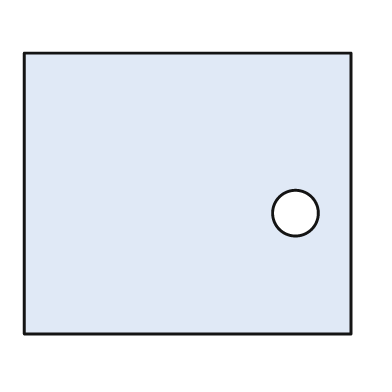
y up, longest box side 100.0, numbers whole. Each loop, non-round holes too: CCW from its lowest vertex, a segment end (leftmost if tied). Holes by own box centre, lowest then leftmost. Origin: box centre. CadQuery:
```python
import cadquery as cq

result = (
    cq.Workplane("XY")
    .moveTo(-50.0, -43.0)
    .lineTo(50.0, -43.0)
    .lineTo(50.0, 43.0)
    .lineTo(-50.0, 43.0)
    .close()
    .moveTo(33.0, -6.0)
    .circle(7.0)
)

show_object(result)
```